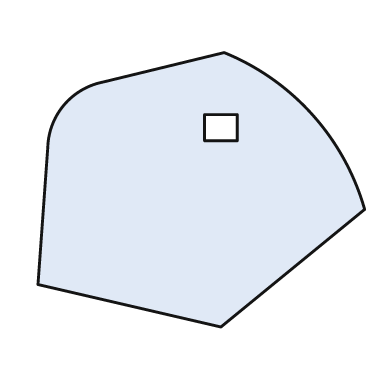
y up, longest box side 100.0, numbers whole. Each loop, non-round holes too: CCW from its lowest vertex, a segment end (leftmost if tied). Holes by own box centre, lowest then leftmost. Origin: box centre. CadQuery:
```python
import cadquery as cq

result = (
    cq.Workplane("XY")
    .moveTo(6.0, -42.0)
    .lineTo(50.0, -6.0)
    .threePointArc((34.0, 23.0), (7.0, 42.0))
    .lineTo(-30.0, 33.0)
    .threePointArc((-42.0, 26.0), (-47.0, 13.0))
    .lineTo(-50.0, -29.0)
    .close()
    .moveTo(1.0, 15.0)
    .lineTo(11.0, 15.0)
    .lineTo(11.0, 23.0)
    .lineTo(1.0, 23.0)
    .close()
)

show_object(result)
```